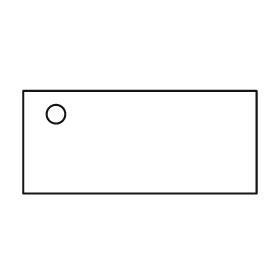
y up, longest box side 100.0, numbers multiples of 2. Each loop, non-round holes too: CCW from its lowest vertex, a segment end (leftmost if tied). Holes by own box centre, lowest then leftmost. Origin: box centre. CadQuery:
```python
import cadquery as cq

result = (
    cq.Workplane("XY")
    .moveTo(-50.0, -22.0)
    .lineTo(50.0, -22.0)
    .lineTo(50.0, 22.0)
    .lineTo(-50.0, 22.0)
    .close()
    .moveTo(-36.0, 12.0)
    .circle(4.0)
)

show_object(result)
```